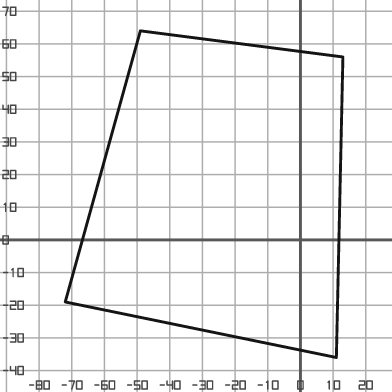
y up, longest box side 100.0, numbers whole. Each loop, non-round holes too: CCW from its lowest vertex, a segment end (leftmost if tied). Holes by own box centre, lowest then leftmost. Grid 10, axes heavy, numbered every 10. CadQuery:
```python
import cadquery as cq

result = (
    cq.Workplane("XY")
    .moveTo(11.0, -36.0)
    .lineTo(13.0, 56.0)
    .lineTo(-49.0, 64.0)
    .lineTo(-72.0, -19.0)
    .close()
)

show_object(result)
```